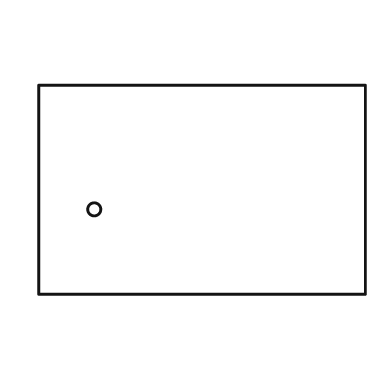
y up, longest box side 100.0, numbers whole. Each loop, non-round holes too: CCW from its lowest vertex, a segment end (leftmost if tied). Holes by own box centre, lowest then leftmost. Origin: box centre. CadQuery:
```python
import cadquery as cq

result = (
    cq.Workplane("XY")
    .moveTo(-50.0, -32.0)
    .lineTo(50.0, -32.0)
    .lineTo(50.0, 32.0)
    .lineTo(-50.0, 32.0)
    .close()
    .moveTo(-33.0, -6.0)
    .circle(2.0)
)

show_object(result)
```